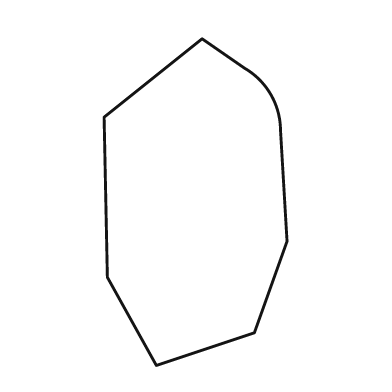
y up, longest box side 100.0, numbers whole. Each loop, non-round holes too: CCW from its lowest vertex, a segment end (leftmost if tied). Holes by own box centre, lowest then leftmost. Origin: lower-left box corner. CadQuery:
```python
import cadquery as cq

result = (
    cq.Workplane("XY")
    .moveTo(16.0, 0.0)
    .lineTo(46.0, 10.0)
    .lineTo(56.0, 38.0)
    .lineTo(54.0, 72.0)
    .threePointArc((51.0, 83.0), (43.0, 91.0))
    .lineTo(30.0, 100.0)
    .lineTo(0.0, 76.0)
    .lineTo(1.0, 27.0)
    .close()
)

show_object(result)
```